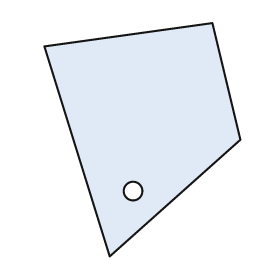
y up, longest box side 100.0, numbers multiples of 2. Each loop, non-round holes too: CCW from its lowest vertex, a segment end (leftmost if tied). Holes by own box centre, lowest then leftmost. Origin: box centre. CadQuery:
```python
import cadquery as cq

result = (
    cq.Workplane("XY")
    .moveTo(-14.0, -50.0)
    .lineTo(42.0, 0.0)
    .lineTo(30.0, 50.0)
    .lineTo(-42.0, 40.0)
    .close()
    .moveTo(-4.0, -22.0)
    .circle(4.0)
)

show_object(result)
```